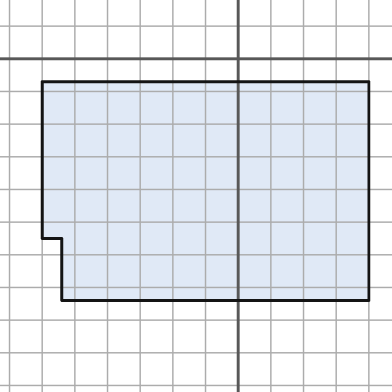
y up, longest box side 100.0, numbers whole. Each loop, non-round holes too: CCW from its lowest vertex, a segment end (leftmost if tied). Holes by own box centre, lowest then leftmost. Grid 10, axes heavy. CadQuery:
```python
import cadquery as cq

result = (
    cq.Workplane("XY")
    .moveTo(-54.0, -74.0)
    .lineTo(40.0, -74.0)
    .lineTo(40.0, -7.0)
    .lineTo(-60.0, -7.0)
    .lineTo(-60.0, -55.0)
    .lineTo(-54.0, -55.0)
    .close()
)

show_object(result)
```